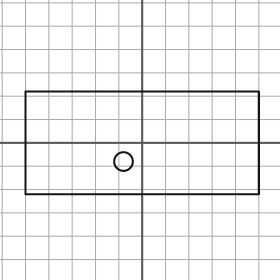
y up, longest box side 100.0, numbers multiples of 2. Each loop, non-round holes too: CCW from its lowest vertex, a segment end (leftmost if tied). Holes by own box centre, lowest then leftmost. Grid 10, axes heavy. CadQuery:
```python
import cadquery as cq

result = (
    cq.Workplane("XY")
    .moveTo(-50.0, -22.0)
    .lineTo(50.0, -22.0)
    .lineTo(50.0, 22.0)
    .lineTo(-50.0, 22.0)
    .close()
    .moveTo(-8.0, -8.0)
    .circle(4.0)
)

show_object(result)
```